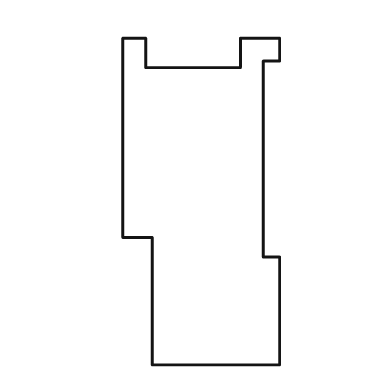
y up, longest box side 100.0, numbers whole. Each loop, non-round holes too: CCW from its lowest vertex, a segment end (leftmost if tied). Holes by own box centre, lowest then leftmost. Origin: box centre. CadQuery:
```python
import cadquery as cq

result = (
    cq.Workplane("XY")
    .moveTo(-15.0, -50.0)
    .lineTo(24.0, -50.0)
    .lineTo(24.0, -17.0)
    .lineTo(19.0, -17.0)
    .lineTo(19.0, 43.0)
    .lineTo(24.0, 43.0)
    .lineTo(24.0, 50.0)
    .lineTo(12.0, 50.0)
    .lineTo(12.0, 41.0)
    .lineTo(-17.0, 41.0)
    .lineTo(-17.0, 50.0)
    .lineTo(-24.0, 50.0)
    .lineTo(-24.0, -11.0)
    .lineTo(-15.0, -11.0)
    .close()
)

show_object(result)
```